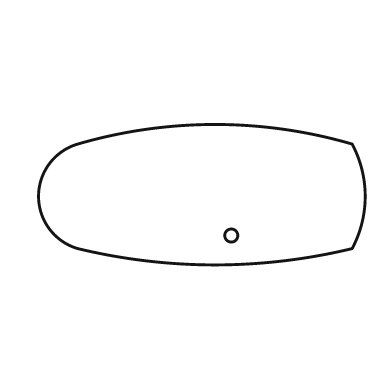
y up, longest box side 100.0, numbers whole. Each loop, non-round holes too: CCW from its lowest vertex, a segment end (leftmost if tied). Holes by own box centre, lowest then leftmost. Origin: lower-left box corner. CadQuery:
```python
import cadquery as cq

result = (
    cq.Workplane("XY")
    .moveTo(12.0, 5.0)
    .threePointArc((54.0, 0.0), (96.0, 5.0))
    .threePointArc((100.0, 21.0), (96.0, 37.0))
    .threePointArc((54.0, 43.0), (12.0, 37.0))
    .threePointArc((0.0, 21.0), (12.0, 5.0))
    .close()
    .moveTo(59.0, 9.0)
    .circle(2.0)
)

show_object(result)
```